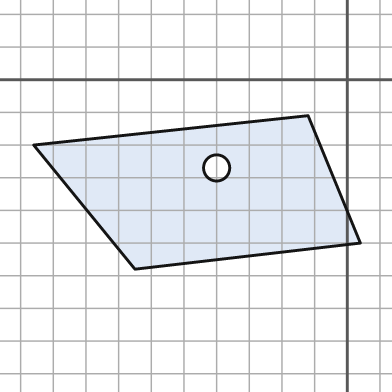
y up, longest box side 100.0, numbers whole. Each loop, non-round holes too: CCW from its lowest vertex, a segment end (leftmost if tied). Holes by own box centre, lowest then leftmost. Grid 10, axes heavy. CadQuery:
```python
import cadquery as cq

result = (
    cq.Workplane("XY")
    .moveTo(-65.0, -58.0)
    .lineTo(4.0, -50.0)
    .lineTo(-12.0, -11.0)
    .lineTo(-96.0, -20.0)
    .close()
    .moveTo(-40.0, -27.0)
    .circle(4.0)
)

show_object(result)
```